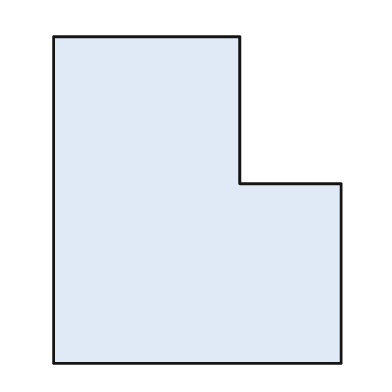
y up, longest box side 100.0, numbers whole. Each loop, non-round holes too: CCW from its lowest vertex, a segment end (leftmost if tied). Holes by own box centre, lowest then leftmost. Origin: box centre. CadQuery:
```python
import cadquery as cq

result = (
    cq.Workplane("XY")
    .moveTo(-44.0, -50.0)
    .lineTo(44.0, -50.0)
    .lineTo(44.0, 5.0)
    .lineTo(13.0, 5.0)
    .lineTo(13.0, 50.0)
    .lineTo(-44.0, 50.0)
    .close()
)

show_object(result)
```